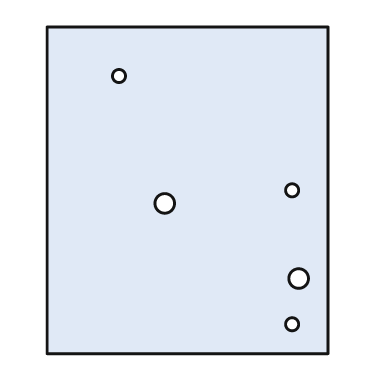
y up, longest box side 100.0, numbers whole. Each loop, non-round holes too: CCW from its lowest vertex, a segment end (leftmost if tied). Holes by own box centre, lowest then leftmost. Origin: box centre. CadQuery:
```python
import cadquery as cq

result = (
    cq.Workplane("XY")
    .moveTo(-43.0, -50.0)
    .lineTo(43.0, -50.0)
    .lineTo(43.0, 50.0)
    .lineTo(-43.0, 50.0)
    .close()
    .moveTo(32.0, -41.0)
    .circle(2.0)
    .moveTo(34.0, -27.0)
    .circle(3.0)
    .moveTo(-7.0, -4.0)
    .circle(3.0)
    .moveTo(32.0, 0.0)
    .circle(2.0)
    .moveTo(-21.0, 35.0)
    .circle(2.0)
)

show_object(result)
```